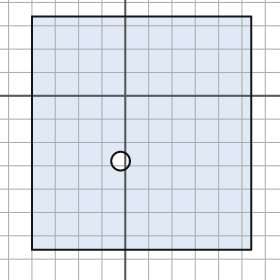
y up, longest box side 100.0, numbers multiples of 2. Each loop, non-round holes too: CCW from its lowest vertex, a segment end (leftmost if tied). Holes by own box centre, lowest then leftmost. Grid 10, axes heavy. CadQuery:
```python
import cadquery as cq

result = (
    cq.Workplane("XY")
    .moveTo(-40.0, -66.0)
    .lineTo(54.0, -66.0)
    .lineTo(54.0, 34.0)
    .lineTo(-40.0, 34.0)
    .close()
    .moveTo(-2.0, -28.0)
    .circle(4.0)
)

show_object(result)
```